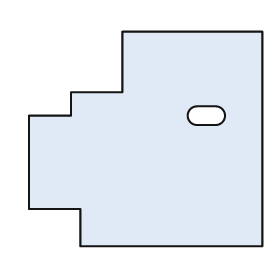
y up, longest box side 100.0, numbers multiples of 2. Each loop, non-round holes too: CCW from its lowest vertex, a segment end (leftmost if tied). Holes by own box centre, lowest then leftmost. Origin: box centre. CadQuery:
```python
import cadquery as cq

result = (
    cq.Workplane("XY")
    .moveTo(-28.0, -46.0)
    .lineTo(50.0, -46.0)
    .lineTo(50.0, 46.0)
    .lineTo(-10.0, 46.0)
    .lineTo(-10.0, 20.0)
    .lineTo(-32.0, 20.0)
    .lineTo(-32.0, 10.0)
    .lineTo(-50.0, 10.0)
    .lineTo(-50.0, -30.0)
    .lineTo(-28.0, -30.0)
    .close()
    .moveTo(22.0, 6.0)
    .lineTo(30.0, 6.0)
    .threePointArc((34.0, 10.0), (30.0, 14.0))
    .lineTo(22.0, 14.0)
    .threePointArc((18.0, 10.0), (22.0, 6.0))
    .close()
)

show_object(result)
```